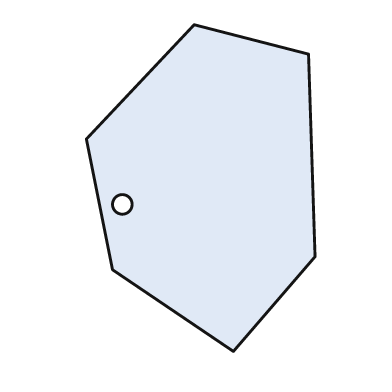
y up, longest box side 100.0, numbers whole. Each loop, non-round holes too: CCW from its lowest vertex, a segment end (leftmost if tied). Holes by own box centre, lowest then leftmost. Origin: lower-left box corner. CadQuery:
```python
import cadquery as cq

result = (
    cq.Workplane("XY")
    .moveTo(45.0, 0.0)
    .lineTo(70.0, 29.0)
    .lineTo(68.0, 91.0)
    .lineTo(33.0, 100.0)
    .lineTo(0.0, 65.0)
    .lineTo(8.0, 25.0)
    .close()
    .moveTo(11.0, 45.0)
    .circle(3.0)
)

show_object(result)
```